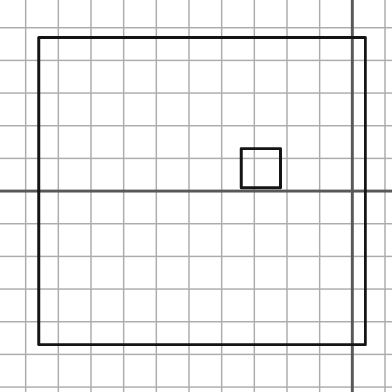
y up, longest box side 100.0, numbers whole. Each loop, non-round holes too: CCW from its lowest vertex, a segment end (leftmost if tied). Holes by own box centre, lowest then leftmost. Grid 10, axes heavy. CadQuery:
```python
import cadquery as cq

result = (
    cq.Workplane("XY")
    .moveTo(-96.0, -47.0)
    .lineTo(4.0, -47.0)
    .lineTo(4.0, 47.0)
    .lineTo(-96.0, 47.0)
    .close()
    .moveTo(-34.0, 1.0)
    .lineTo(-22.0, 1.0)
    .lineTo(-22.0, 13.0)
    .lineTo(-34.0, 13.0)
    .close()
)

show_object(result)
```